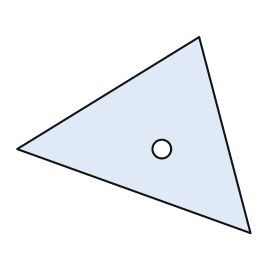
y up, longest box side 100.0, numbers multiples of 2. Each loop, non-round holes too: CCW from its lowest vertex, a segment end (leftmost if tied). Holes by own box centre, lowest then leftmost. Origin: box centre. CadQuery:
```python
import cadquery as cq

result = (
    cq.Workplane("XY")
    .moveTo(50.0, -42.0)
    .lineTo(28.0, 42.0)
    .lineTo(-50.0, -6.0)
    .close()
    .moveTo(12.0, -6.0)
    .circle(4.0)
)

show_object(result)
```